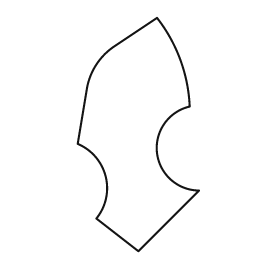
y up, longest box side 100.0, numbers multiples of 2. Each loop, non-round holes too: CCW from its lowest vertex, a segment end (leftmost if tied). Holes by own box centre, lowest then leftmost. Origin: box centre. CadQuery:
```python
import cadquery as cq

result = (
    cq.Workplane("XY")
    .moveTo(0.0, -50.0)
    .lineTo(26.0, -24.0)
    .threePointArc((8.0, -8.0), (22.0, 12.0))
    .threePointArc((18.0, 32.0), (8.0, 50.0))
    .lineTo(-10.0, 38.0)
    .threePointArc((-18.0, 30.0), (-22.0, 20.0))
    .lineTo(-26.0, -4.0)
    .threePointArc((-14.0, -18.0), (-18.0, -36.0))
    .close()
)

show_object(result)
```